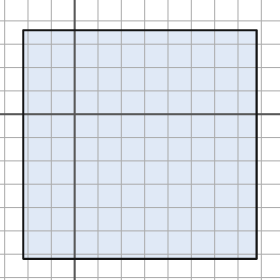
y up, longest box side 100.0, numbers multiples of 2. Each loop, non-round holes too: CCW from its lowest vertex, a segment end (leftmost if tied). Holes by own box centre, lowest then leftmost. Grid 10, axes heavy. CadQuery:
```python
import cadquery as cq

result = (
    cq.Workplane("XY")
    .moveTo(-22.0, -62.0)
    .lineTo(78.0, -62.0)
    .lineTo(78.0, 36.0)
    .lineTo(-22.0, 36.0)
    .close()
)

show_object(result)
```